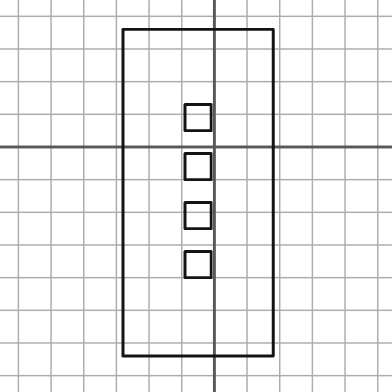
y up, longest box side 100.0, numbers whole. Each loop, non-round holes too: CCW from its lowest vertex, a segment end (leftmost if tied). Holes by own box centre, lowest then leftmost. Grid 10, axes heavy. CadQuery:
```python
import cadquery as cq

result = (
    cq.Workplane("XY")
    .moveTo(-28.0, -64.0)
    .lineTo(18.0, -64.0)
    .lineTo(18.0, 36.0)
    .lineTo(-28.0, 36.0)
    .close()
    .moveTo(-9.0, -40.0)
    .lineTo(-1.0, -40.0)
    .lineTo(-1.0, -32.0)
    .lineTo(-9.0, -32.0)
    .close()
    .moveTo(-9.0, -25.0)
    .lineTo(-1.0, -25.0)
    .lineTo(-1.0, -17.0)
    .lineTo(-9.0, -17.0)
    .close()
    .moveTo(-9.0, -10.0)
    .lineTo(-1.0, -10.0)
    .lineTo(-1.0, -2.0)
    .lineTo(-9.0, -2.0)
    .close()
    .moveTo(-9.0, 5.0)
    .lineTo(-1.0, 5.0)
    .lineTo(-1.0, 13.0)
    .lineTo(-9.0, 13.0)
    .close()
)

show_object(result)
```